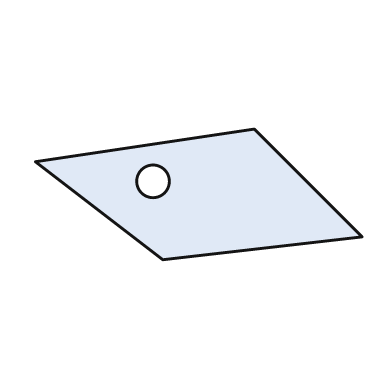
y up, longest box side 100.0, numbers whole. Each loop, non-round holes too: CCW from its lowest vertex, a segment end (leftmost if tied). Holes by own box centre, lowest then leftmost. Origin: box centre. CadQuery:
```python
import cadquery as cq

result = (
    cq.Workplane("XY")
    .moveTo(-11.0, -20.0)
    .lineTo(50.0, -13.0)
    .lineTo(17.0, 20.0)
    .lineTo(-50.0, 10.0)
    .close()
    .moveTo(-14.0, 4.0)
    .circle(5.0)
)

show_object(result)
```